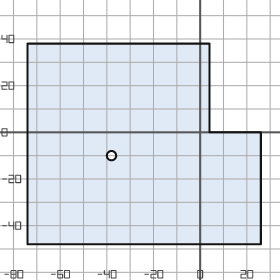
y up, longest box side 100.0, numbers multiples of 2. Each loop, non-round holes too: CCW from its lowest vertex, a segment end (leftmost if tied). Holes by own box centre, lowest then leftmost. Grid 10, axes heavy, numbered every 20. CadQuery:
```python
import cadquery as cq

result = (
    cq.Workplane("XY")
    .moveTo(-74.0, -48.0)
    .lineTo(26.0, -48.0)
    .lineTo(26.0, 0.0)
    .lineTo(4.0, 0.0)
    .lineTo(4.0, 38.0)
    .lineTo(-74.0, 38.0)
    .close()
    .moveTo(-38.0, -10.0)
    .circle(2.0)
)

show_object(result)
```